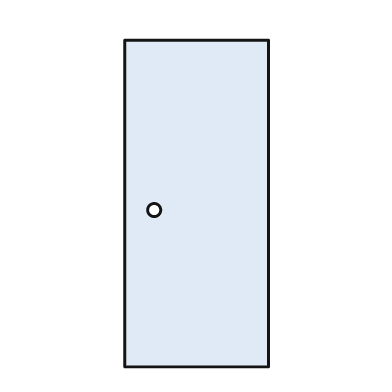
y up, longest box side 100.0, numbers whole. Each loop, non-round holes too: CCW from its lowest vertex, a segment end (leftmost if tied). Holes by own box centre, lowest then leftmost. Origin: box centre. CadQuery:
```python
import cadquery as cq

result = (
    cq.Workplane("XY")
    .moveTo(-22.0, -50.0)
    .lineTo(22.0, -50.0)
    .lineTo(22.0, 50.0)
    .lineTo(-22.0, 50.0)
    .close()
    .moveTo(-13.0, -2.0)
    .circle(2.0)
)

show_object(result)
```